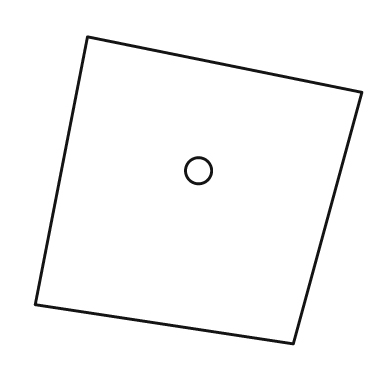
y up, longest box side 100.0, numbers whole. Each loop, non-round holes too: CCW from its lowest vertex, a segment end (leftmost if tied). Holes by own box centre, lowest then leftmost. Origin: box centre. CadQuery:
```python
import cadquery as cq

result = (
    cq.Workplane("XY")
    .moveTo(29.0, -47.0)
    .lineTo(50.0, 30.0)
    .lineTo(-34.0, 47.0)
    .lineTo(-50.0, -35.0)
    .close()
    .moveTo(0.0, 6.0)
    .circle(4.0)
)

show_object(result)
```